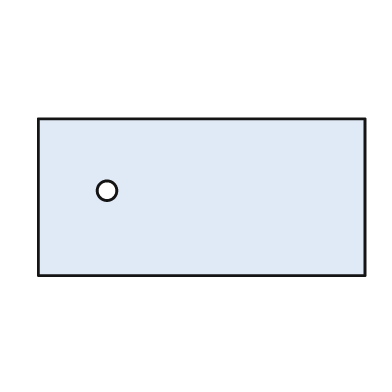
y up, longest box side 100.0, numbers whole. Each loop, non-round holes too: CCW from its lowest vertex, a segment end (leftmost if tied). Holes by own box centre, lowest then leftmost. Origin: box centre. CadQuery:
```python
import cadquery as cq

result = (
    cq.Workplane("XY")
    .moveTo(-50.0, -24.0)
    .lineTo(50.0, -24.0)
    .lineTo(50.0, 24.0)
    .lineTo(-50.0, 24.0)
    .close()
    .moveTo(-29.0, 2.0)
    .circle(3.0)
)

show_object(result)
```